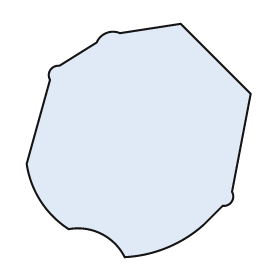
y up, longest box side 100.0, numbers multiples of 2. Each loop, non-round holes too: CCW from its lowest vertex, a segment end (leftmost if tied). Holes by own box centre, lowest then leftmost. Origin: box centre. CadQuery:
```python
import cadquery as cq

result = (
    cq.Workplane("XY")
    .moveTo(-6.0, -50.0)
    .threePointArc((12.0, -46.0), (28.0, -36.0))
    .lineTo(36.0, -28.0)
    .threePointArc((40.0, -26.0), (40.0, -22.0))
    .lineTo(48.0, 20.0)
    .lineTo(18.0, 50.0)
    .lineTo(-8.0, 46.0)
    .threePointArc((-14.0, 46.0), (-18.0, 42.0))
    .lineTo(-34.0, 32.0)
    .threePointArc((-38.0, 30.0), (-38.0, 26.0))
    .lineTo(-48.0, -10.0)
    .threePointArc((-42.0, -26.0), (-30.0, -38.0))
    .threePointArc((-16.0, -40.0), (-6.0, -50.0))
    .close()
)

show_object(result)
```